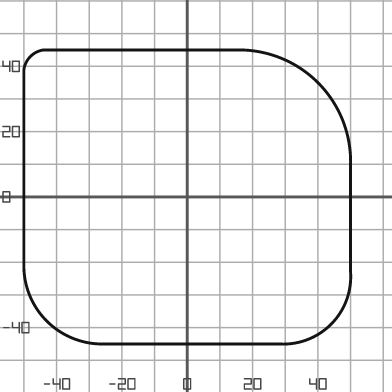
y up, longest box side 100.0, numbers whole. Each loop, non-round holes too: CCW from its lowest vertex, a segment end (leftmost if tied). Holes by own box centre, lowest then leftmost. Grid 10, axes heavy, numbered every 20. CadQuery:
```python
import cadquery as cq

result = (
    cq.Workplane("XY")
    .moveTo(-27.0, -45.0)
    .lineTo(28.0, -45.0)
    .threePointArc((44.0, -39.0), (50.0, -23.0))
    .lineTo(50.0, 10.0)
    .threePointArc((40.0, 35.0), (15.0, 45.0))
    .lineTo(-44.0, 45.0)
    .threePointArc((-48.0, 43.0), (-50.0, 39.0))
    .lineTo(-50.0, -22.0)
    .threePointArc((-43.0, -38.0), (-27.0, -45.0))
    .close()
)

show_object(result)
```